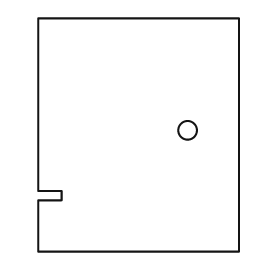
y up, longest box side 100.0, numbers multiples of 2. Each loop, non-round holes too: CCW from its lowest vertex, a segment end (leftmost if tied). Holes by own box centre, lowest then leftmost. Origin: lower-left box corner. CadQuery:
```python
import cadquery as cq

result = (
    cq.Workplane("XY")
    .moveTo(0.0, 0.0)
    .lineTo(86.0, 0.0)
    .lineTo(86.0, 100.0)
    .lineTo(0.0, 100.0)
    .lineTo(0.0, 26.0)
    .lineTo(10.0, 26.0)
    .lineTo(10.0, 22.0)
    .lineTo(0.0, 22.0)
    .close()
    .moveTo(64.0, 52.0)
    .circle(4.0)
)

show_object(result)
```